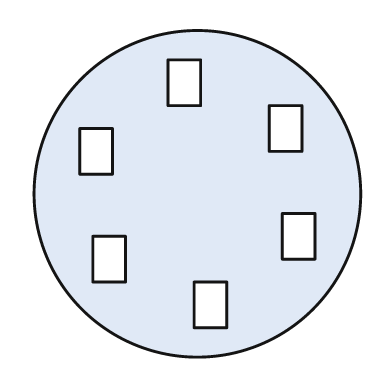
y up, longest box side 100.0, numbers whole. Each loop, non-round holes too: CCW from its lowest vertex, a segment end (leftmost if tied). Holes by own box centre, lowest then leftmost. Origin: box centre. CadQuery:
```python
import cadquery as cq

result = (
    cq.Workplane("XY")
    .moveTo(0.0, 0.0)
    .circle(50.0)
    .moveTo(-1.0, -41.0)
    .lineTo(9.0, -41.0)
    .lineTo(9.0, -27.0)
    .lineTo(-1.0, -27.0)
    .close()
    .moveTo(-32.0, -27.0)
    .lineTo(-22.0, -27.0)
    .lineTo(-22.0, -13.0)
    .lineTo(-32.0, -13.0)
    .close()
    .moveTo(26.0, -20.0)
    .lineTo(36.0, -20.0)
    .lineTo(36.0, -6.0)
    .lineTo(26.0, -6.0)
    .close()
    .moveTo(-36.0, 6.0)
    .lineTo(-26.0, 6.0)
    .lineTo(-26.0, 20.0)
    .lineTo(-36.0, 20.0)
    .close()
    .moveTo(22.0, 13.0)
    .lineTo(32.0, 13.0)
    .lineTo(32.0, 27.0)
    .lineTo(22.0, 27.0)
    .close()
    .moveTo(-9.0, 27.0)
    .lineTo(1.0, 27.0)
    .lineTo(1.0, 41.0)
    .lineTo(-9.0, 41.0)
    .close()
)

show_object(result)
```